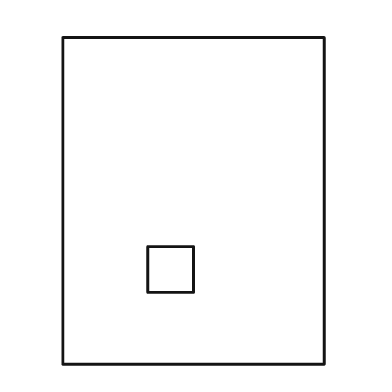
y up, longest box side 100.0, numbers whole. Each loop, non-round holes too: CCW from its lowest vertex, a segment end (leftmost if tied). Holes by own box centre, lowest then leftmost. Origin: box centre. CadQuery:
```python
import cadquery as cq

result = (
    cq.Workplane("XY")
    .moveTo(-40.0, -50.0)
    .lineTo(40.0, -50.0)
    .lineTo(40.0, 50.0)
    .lineTo(-40.0, 50.0)
    .close()
    .moveTo(-14.0, -28.0)
    .lineTo(0.0, -28.0)
    .lineTo(0.0, -14.0)
    .lineTo(-14.0, -14.0)
    .close()
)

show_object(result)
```